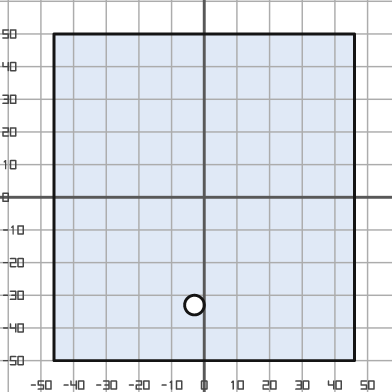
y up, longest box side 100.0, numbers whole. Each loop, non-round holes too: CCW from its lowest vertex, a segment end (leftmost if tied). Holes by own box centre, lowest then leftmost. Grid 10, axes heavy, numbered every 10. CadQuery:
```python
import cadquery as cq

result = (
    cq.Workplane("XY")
    .moveTo(-46.0, -50.0)
    .lineTo(46.0, -50.0)
    .lineTo(46.0, 50.0)
    .lineTo(-46.0, 50.0)
    .close()
    .moveTo(-3.0, -33.0)
    .circle(3.0)
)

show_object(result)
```